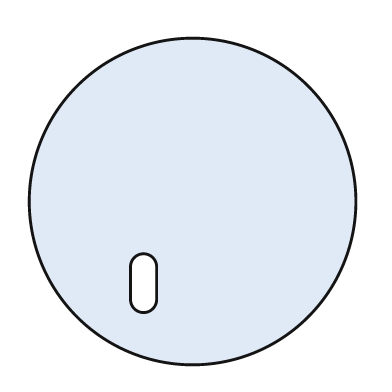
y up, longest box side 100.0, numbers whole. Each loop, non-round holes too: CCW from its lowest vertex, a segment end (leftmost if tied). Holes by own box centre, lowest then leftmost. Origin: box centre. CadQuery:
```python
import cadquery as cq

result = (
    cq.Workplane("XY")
    .moveTo(0.0, 0.0)
    .circle(50.0)
    .moveTo(-19.0, -30.0)
    .threePointArc((-15.0, -34.0), (-11.0, -30.0))
    .lineTo(-11.0, -20.0)
    .threePointArc((-15.0, -16.0), (-19.0, -20.0))
    .close()
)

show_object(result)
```